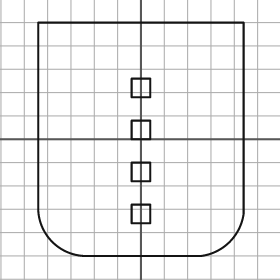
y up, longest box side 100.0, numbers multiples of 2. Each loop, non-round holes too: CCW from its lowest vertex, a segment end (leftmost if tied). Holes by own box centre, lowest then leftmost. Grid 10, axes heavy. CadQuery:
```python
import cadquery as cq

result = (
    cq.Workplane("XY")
    .moveTo(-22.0, -50.0)
    .lineTo(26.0, -50.0)
    .threePointArc((38.0, -44.0), (44.0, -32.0))
    .lineTo(44.0, 50.0)
    .lineTo(-44.0, 50.0)
    .lineTo(-44.0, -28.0)
    .threePointArc((-38.0, -44.0), (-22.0, -50.0))
    .close()
    .moveTo(-4.0, -36.0)
    .lineTo(4.0, -36.0)
    .lineTo(4.0, -28.0)
    .lineTo(-4.0, -28.0)
    .close()
    .moveTo(-4.0, -18.0)
    .lineTo(4.0, -18.0)
    .lineTo(4.0, -10.0)
    .lineTo(-4.0, -10.0)
    .close()
    .moveTo(-4.0, 0.0)
    .lineTo(4.0, 0.0)
    .lineTo(4.0, 8.0)
    .lineTo(-4.0, 8.0)
    .close()
    .moveTo(-4.0, 18.0)
    .lineTo(4.0, 18.0)
    .lineTo(4.0, 26.0)
    .lineTo(-4.0, 26.0)
    .close()
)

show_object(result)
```